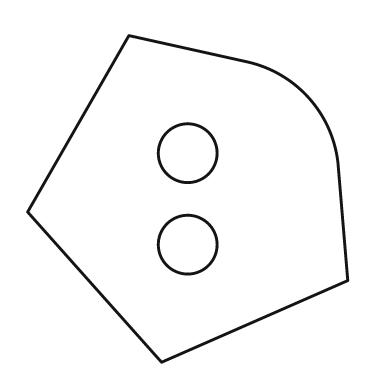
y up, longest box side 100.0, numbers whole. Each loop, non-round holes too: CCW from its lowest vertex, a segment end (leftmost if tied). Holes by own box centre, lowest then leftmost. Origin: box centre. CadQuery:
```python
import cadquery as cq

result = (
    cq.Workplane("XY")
    .moveTo(-8.0, -50.0)
    .lineTo(49.0, -25.0)
    .lineTo(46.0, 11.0)
    .threePointArc((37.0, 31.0), (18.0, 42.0))
    .lineTo(-18.0, 50.0)
    .lineTo(-49.0, -4.0)
    .close()
    .moveTo(0.0, -14.0)
    .circle(9.0)
    .moveTo(0.0, 14.0)
    .circle(9.0)
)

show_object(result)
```